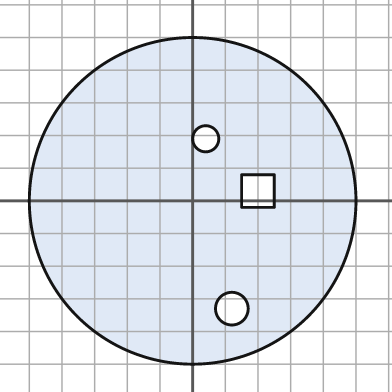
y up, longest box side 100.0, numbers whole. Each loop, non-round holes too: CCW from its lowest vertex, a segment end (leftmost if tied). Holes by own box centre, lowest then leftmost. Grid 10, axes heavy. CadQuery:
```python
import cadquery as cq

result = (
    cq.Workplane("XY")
    .moveTo(0.0, 0.0)
    .circle(50.0)
    .moveTo(12.0, -33.0)
    .circle(5.0)
    .moveTo(15.0, -2.0)
    .lineTo(25.0, -2.0)
    .lineTo(25.0, 8.0)
    .lineTo(15.0, 8.0)
    .close()
    .moveTo(4.0, 19.0)
    .circle(4.0)
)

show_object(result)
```